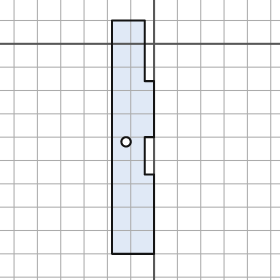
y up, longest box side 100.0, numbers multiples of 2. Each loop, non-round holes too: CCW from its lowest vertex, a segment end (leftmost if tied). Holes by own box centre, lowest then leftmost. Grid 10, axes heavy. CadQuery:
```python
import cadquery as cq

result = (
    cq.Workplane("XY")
    .moveTo(-18.0, -90.0)
    .lineTo(0.0, -90.0)
    .lineTo(0.0, -56.0)
    .lineTo(-4.0, -56.0)
    .lineTo(-4.0, -40.0)
    .lineTo(0.0, -40.0)
    .lineTo(0.0, -16.0)
    .lineTo(-4.0, -16.0)
    .lineTo(-4.0, 10.0)
    .lineTo(-18.0, 10.0)
    .close()
    .moveTo(-12.0, -42.0)
    .circle(2.0)
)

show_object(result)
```